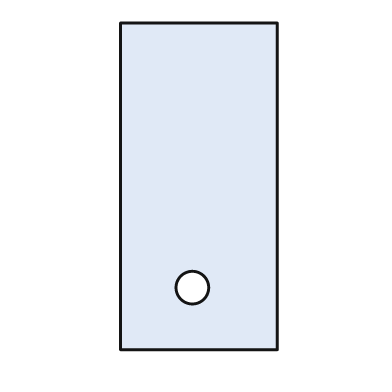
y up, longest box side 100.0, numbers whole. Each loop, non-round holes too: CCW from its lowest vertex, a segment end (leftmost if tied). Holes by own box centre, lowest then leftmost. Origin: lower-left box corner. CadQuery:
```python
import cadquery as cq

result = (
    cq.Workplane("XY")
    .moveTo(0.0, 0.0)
    .lineTo(48.0, 0.0)
    .lineTo(48.0, 100.0)
    .lineTo(0.0, 100.0)
    .close()
    .moveTo(22.0, 19.0)
    .circle(5.0)
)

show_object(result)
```